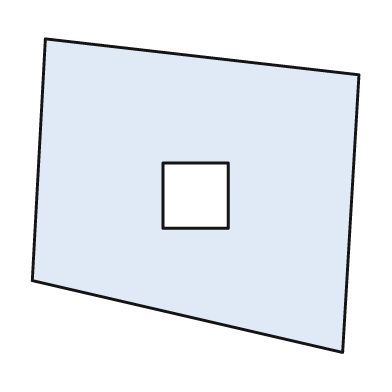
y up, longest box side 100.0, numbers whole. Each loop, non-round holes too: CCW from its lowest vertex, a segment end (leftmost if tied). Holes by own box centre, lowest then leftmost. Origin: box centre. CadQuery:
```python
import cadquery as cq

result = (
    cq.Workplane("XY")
    .moveTo(45.0, -48.0)
    .lineTo(50.0, 37.0)
    .lineTo(-46.0, 48.0)
    .lineTo(-50.0, -26.0)
    .close()
    .moveTo(-10.0, -10.0)
    .lineTo(10.0, -10.0)
    .lineTo(10.0, 10.0)
    .lineTo(-10.0, 10.0)
    .close()
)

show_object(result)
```